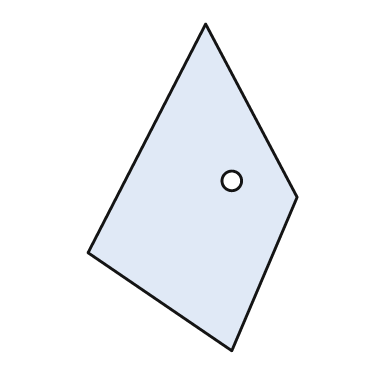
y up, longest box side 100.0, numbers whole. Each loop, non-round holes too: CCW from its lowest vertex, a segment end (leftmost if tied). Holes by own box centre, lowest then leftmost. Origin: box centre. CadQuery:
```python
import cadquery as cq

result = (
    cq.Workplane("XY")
    .moveTo(12.0, -50.0)
    .lineTo(32.0, -3.0)
    .lineTo(4.0, 50.0)
    .lineTo(-32.0, -20.0)
    .close()
    .moveTo(12.0, 2.0)
    .circle(3.0)
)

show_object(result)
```